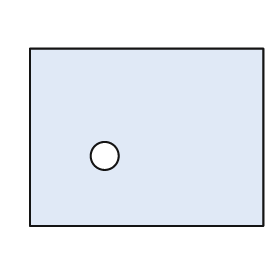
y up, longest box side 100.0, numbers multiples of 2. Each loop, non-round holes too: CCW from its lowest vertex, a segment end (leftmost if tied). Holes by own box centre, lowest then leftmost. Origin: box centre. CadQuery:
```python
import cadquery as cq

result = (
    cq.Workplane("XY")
    .moveTo(-50.0, -38.0)
    .lineTo(50.0, -38.0)
    .lineTo(50.0, 38.0)
    .lineTo(-50.0, 38.0)
    .close()
    .moveTo(-18.0, -8.0)
    .circle(6.0)
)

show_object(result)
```